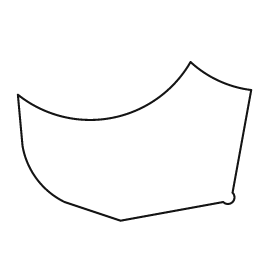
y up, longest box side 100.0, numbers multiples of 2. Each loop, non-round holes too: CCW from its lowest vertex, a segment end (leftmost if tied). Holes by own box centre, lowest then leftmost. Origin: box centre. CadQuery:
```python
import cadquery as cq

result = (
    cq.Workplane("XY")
    .moveTo(-6.0, -34.0)
    .lineTo(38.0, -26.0)
    .threePointArc((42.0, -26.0), (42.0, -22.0))
    .lineTo(50.0, 22.0)
    .threePointArc((36.0, 26.0), (24.0, 34.0))
    .threePointArc((-10.0, 10.0), (-50.0, 20.0))
    .lineTo(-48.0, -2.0)
    .threePointArc((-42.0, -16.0), (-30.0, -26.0))
    .close()
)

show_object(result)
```